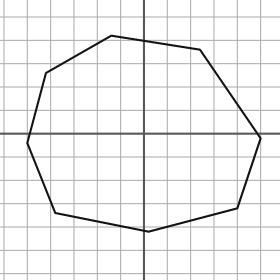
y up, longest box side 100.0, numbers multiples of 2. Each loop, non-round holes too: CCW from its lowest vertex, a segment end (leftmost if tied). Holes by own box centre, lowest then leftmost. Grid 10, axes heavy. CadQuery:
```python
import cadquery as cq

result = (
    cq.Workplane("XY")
    .moveTo(2.0, -42.0)
    .lineTo(40.0, -32.0)
    .lineTo(50.0, -2.0)
    .lineTo(24.0, 36.0)
    .lineTo(-14.0, 42.0)
    .lineTo(-42.0, 26.0)
    .lineTo(-50.0, -4.0)
    .lineTo(-38.0, -34.0)
    .close()
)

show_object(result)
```